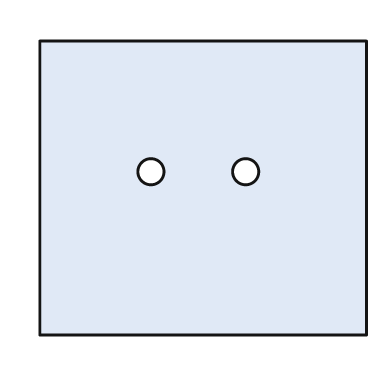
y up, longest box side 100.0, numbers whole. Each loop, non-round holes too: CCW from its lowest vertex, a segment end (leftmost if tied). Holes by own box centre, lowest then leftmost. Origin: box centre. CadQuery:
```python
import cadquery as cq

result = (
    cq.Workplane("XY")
    .moveTo(-50.0, -45.0)
    .lineTo(50.0, -45.0)
    .lineTo(50.0, 45.0)
    .lineTo(-50.0, 45.0)
    .close()
    .moveTo(-16.0, 5.0)
    .circle(4.0)
    .moveTo(13.0, 5.0)
    .circle(4.0)
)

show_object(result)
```